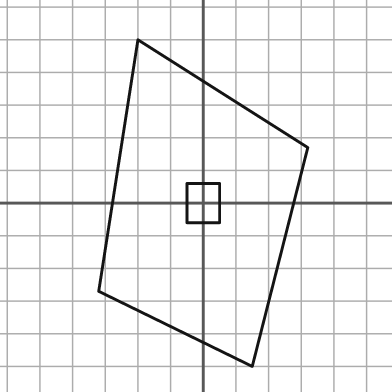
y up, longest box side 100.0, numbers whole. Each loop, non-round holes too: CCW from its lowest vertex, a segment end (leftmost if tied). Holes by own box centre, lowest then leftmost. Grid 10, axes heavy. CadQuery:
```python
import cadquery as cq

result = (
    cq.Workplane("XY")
    .moveTo(15.0, -50.0)
    .lineTo(32.0, 17.0)
    .lineTo(-20.0, 50.0)
    .lineTo(-32.0, -27.0)
    .close()
    .moveTo(-5.0, -6.0)
    .lineTo(5.0, -6.0)
    .lineTo(5.0, 6.0)
    .lineTo(-5.0, 6.0)
    .close()
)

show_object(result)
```